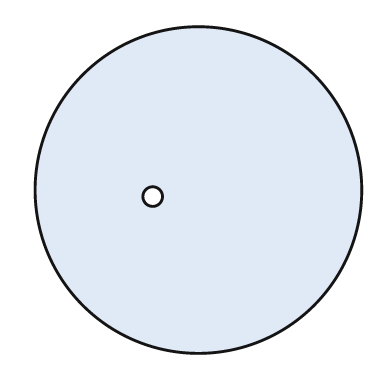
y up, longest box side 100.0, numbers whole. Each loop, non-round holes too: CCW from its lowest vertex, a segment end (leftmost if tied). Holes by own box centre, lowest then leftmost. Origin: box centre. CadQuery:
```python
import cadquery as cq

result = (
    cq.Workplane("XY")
    .moveTo(0.0, 0.0)
    .circle(50.0)
    .moveTo(-14.0, -2.0)
    .circle(3.0)
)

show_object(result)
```